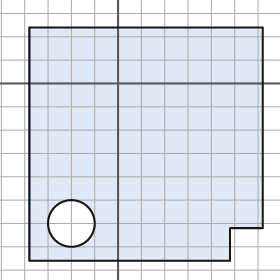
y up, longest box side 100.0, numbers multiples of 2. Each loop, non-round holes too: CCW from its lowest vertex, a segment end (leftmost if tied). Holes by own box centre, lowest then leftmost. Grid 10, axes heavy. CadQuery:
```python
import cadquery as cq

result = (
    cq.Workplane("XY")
    .moveTo(-38.0, -76.0)
    .lineTo(48.0, -76.0)
    .lineTo(48.0, -62.0)
    .lineTo(62.0, -62.0)
    .lineTo(62.0, 24.0)
    .lineTo(-38.0, 24.0)
    .close()
    .moveTo(-20.0, -60.0)
    .circle(10.0)
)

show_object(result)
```